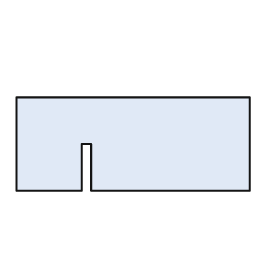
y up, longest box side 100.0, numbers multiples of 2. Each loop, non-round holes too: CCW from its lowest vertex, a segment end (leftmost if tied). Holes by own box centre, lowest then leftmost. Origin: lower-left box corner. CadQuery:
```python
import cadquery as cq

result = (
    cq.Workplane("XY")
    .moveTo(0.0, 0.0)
    .lineTo(28.0, 0.0)
    .lineTo(28.0, 20.0)
    .lineTo(32.0, 20.0)
    .lineTo(32.0, 0.0)
    .lineTo(100.0, 0.0)
    .lineTo(100.0, 40.0)
    .lineTo(0.0, 40.0)
    .close()
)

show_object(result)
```